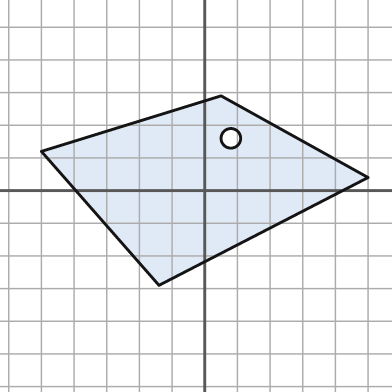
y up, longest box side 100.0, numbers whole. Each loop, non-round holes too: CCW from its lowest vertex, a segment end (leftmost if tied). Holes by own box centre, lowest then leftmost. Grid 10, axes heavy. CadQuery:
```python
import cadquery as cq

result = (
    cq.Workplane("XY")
    .moveTo(-14.0, -29.0)
    .lineTo(50.0, 4.0)
    .lineTo(5.0, 29.0)
    .lineTo(-50.0, 12.0)
    .close()
    .moveTo(8.0, 16.0)
    .circle(3.0)
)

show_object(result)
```